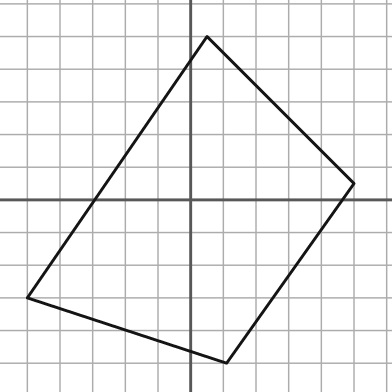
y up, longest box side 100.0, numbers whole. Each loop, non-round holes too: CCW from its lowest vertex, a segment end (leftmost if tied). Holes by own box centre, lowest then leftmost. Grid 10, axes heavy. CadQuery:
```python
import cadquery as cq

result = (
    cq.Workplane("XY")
    .moveTo(11.0, -50.0)
    .lineTo(50.0, 5.0)
    .lineTo(5.0, 50.0)
    .lineTo(-50.0, -30.0)
    .close()
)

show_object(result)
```